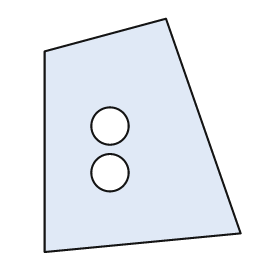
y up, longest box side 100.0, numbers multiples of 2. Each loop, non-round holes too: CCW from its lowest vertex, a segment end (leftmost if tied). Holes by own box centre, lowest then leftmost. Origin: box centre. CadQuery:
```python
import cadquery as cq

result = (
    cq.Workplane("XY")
    .moveTo(-42.0, -50.0)
    .lineTo(42.0, -42.0)
    .lineTo(10.0, 50.0)
    .lineTo(-42.0, 36.0)
    .close()
    .moveTo(-14.0, -16.0)
    .circle(8.0)
    .moveTo(-14.0, 4.0)
    .circle(8.0)
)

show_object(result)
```